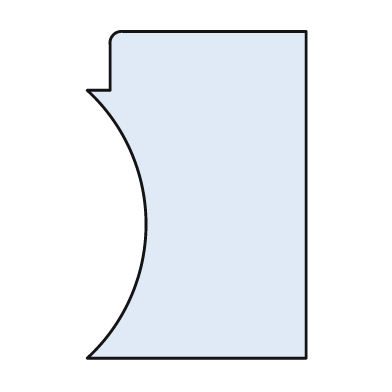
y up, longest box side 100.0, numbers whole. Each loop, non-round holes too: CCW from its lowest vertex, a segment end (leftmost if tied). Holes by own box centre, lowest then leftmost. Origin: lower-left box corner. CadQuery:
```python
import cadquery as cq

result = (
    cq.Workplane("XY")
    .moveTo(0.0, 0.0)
    .lineTo(67.0, 0.0)
    .lineTo(67.0, 100.0)
    .lineTo(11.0, 100.0)
    .threePointArc((8.0, 99.0), (7.0, 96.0))
    .lineTo(7.0, 82.0)
    .lineTo(0.0, 82.0)
    .threePointArc((18.0, 41.0), (0.0, 0.0))
    .close()
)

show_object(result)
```